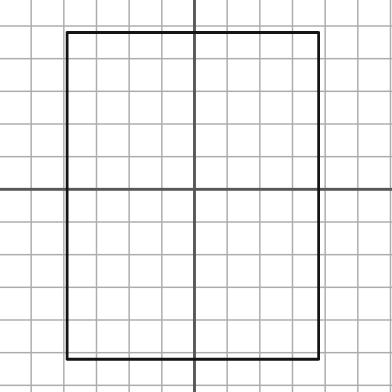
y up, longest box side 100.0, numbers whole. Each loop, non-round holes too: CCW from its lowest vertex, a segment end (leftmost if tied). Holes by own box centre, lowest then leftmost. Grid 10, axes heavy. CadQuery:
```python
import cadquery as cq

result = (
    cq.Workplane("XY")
    .moveTo(-39.0, -52.0)
    .lineTo(38.0, -52.0)
    .lineTo(38.0, 48.0)
    .lineTo(-39.0, 48.0)
    .close()
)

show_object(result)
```